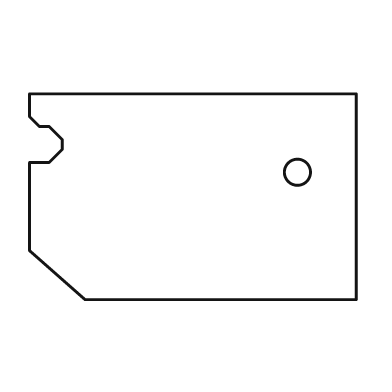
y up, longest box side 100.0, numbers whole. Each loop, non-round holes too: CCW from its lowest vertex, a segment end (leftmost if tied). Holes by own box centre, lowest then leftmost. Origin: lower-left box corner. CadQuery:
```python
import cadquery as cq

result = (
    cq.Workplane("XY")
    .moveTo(17.0, 0.0)
    .lineTo(100.0, 0.0)
    .lineTo(100.0, 63.0)
    .lineTo(0.0, 63.0)
    .lineTo(0.0, 56.0)
    .lineTo(3.0, 53.0)
    .lineTo(6.0, 53.0)
    .lineTo(10.0, 49.0)
    .lineTo(10.0, 46.0)
    .lineTo(6.0, 42.0)
    .lineTo(0.0, 42.0)
    .lineTo(0.0, 15.0)
    .close()
    .moveTo(82.0, 39.0)
    .circle(4.0)
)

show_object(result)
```